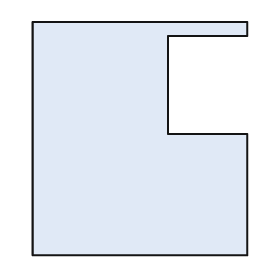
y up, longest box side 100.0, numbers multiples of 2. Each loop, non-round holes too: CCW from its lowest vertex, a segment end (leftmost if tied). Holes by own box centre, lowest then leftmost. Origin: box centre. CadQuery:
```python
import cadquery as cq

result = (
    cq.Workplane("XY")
    .moveTo(-46.0, -50.0)
    .lineTo(46.0, -50.0)
    .lineTo(46.0, 2.0)
    .lineTo(12.0, 2.0)
    .lineTo(12.0, 44.0)
    .lineTo(46.0, 44.0)
    .lineTo(46.0, 50.0)
    .lineTo(-46.0, 50.0)
    .close()
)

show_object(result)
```